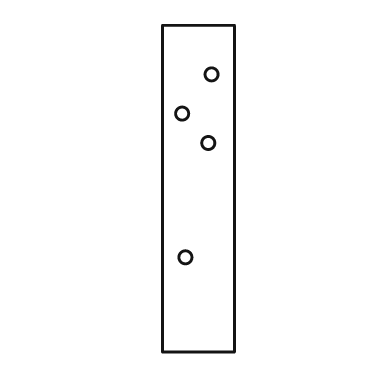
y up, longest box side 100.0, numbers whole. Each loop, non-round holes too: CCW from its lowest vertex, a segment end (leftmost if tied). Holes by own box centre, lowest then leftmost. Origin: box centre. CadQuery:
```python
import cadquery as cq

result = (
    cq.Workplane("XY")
    .moveTo(-11.0, -50.0)
    .lineTo(11.0, -50.0)
    .lineTo(11.0, 50.0)
    .lineTo(-11.0, 50.0)
    .close()
    .moveTo(-4.0, -21.0)
    .circle(2.0)
    .moveTo(3.0, 14.0)
    .circle(2.0)
    .moveTo(-5.0, 23.0)
    .circle(2.0)
    .moveTo(4.0, 35.0)
    .circle(2.0)
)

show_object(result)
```